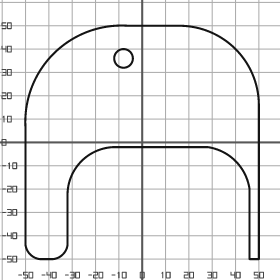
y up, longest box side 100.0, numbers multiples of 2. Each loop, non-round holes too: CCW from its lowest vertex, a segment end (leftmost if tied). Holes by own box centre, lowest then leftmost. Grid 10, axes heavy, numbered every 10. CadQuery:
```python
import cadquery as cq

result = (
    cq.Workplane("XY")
    .moveTo(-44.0, -50.0)
    .lineTo(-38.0, -50.0)
    .threePointArc((-34.0, -48.0), (-32.0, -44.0))
    .lineTo(-32.0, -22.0)
    .threePointArc((-26.0, -8.0), (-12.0, -2.0))
    .lineTo(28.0, -2.0)
    .threePointArc((40.0, -8.0), (46.0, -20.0))
    .lineTo(46.0, -50.0)
    .lineTo(50.0, -50.0)
    .lineTo(50.0, 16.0)
    .threePointArc((40.0, 40.0), (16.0, 50.0))
    .lineTo(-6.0, 50.0)
    .threePointArc((-38.0, 38.0), (-50.0, 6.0))
    .lineTo(-50.0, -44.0)
    .threePointArc((-48.0, -48.0), (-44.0, -50.0))
    .close()
    .moveTo(-8.0, 36.0)
    .circle(4.0)
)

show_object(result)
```